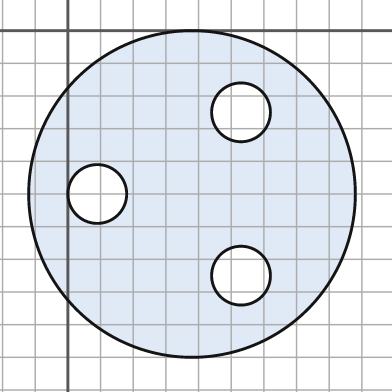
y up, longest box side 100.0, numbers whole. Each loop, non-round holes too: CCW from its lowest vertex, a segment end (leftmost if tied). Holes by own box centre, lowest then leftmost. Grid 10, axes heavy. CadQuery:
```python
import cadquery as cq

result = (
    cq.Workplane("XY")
    .moveTo(38.0, -50.0)
    .circle(50.0)
    .moveTo(53.0, -75.0)
    .circle(9.0)
    .moveTo(9.0, -50.0)
    .circle(9.0)
    .moveTo(53.0, -25.0)
    .circle(9.0)
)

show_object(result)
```